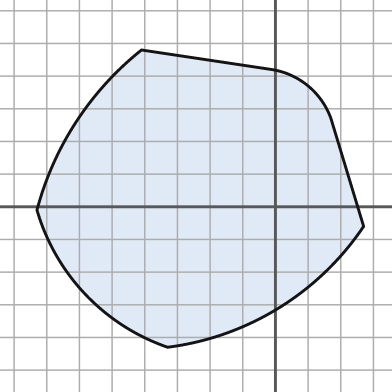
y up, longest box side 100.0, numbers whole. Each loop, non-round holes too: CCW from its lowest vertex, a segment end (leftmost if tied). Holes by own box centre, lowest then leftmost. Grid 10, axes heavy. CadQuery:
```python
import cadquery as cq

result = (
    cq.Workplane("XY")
    .moveTo(-33.0, -43.0)
    .threePointArc((1.0, -31.0), (27.0, -6.0))
    .lineTo(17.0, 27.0)
    .threePointArc((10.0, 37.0), (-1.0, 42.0))
    .lineTo(-41.0, 48.0)
    .threePointArc((-61.0, 26.0), (-73.0, -1.0))
    .threePointArc((-58.0, -27.0), (-33.0, -43.0))
    .close()
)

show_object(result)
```